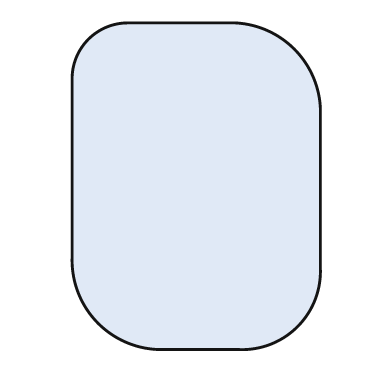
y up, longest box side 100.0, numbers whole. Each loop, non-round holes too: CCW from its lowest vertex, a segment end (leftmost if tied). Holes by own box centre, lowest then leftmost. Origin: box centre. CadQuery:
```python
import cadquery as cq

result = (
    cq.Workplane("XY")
    .moveTo(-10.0, -50.0)
    .lineTo(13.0, -50.0)
    .threePointArc((31.0, -43.0), (38.0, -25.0))
    .lineTo(38.0, 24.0)
    .threePointArc((30.0, 42.0), (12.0, 50.0))
    .lineTo(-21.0, 50.0)
    .threePointArc((-33.0, 45.0), (-38.0, 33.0))
    .lineTo(-38.0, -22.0)
    .threePointArc((-30.0, -42.0), (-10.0, -50.0))
    .close()
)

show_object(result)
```